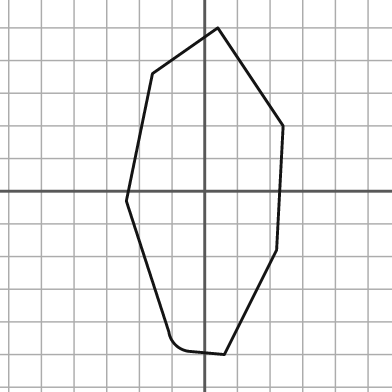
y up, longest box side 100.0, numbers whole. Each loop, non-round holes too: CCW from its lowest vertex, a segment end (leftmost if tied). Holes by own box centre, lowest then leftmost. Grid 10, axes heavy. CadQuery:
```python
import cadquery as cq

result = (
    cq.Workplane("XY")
    .moveTo(6.0, -50.0)
    .lineTo(22.0, -18.0)
    .lineTo(24.0, 20.0)
    .lineTo(4.0, 50.0)
    .lineTo(-16.0, 36.0)
    .lineTo(-24.0, -3.0)
    .lineTo(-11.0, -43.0)
    .threePointArc((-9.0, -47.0), (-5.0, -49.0))
    .close()
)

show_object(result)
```